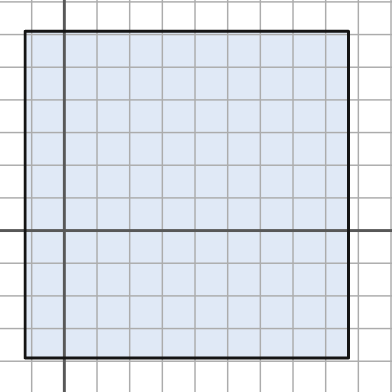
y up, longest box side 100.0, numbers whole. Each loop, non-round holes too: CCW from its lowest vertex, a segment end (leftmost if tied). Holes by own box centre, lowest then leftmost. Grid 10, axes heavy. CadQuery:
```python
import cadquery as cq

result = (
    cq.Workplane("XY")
    .moveTo(-12.0, -39.0)
    .lineTo(87.0, -39.0)
    .lineTo(87.0, 61.0)
    .lineTo(-12.0, 61.0)
    .close()
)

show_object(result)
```